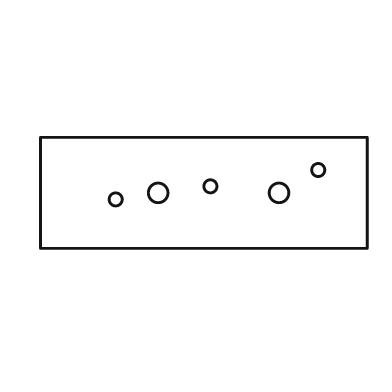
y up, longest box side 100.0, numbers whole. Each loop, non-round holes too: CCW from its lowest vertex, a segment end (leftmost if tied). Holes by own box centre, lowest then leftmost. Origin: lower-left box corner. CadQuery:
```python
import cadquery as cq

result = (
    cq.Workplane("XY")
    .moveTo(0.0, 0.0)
    .lineTo(100.0, 0.0)
    .lineTo(100.0, 34.0)
    .lineTo(0.0, 34.0)
    .close()
    .moveTo(23.0, 15.0)
    .circle(2.0)
    .moveTo(36.0, 17.0)
    .circle(3.0)
    .moveTo(73.0, 17.0)
    .circle(3.0)
    .moveTo(52.0, 19.0)
    .circle(2.0)
    .moveTo(85.0, 24.0)
    .circle(2.0)
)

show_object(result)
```